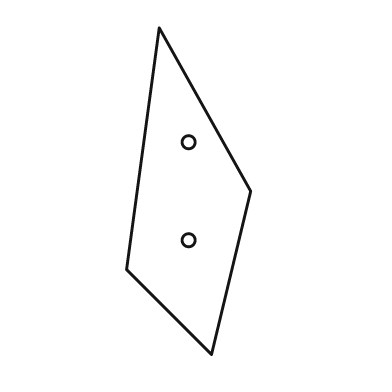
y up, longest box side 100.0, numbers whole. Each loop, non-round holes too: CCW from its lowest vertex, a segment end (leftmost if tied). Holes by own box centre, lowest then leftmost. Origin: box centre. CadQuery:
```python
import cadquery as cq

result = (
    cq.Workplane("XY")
    .moveTo(7.0, -50.0)
    .lineTo(19.0, 0.0)
    .lineTo(-9.0, 50.0)
    .lineTo(-19.0, -24.0)
    .close()
    .moveTo(0.0, -15.0)
    .circle(2.0)
    .moveTo(0.0, 15.0)
    .circle(2.0)
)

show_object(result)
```